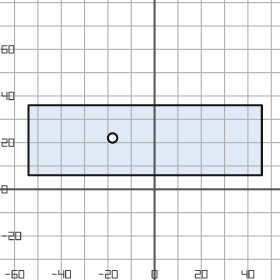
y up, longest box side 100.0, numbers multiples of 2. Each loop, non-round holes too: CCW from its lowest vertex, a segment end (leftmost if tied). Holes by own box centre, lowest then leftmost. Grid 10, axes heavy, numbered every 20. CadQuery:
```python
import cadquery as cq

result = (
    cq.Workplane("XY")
    .moveTo(-54.0, 6.0)
    .lineTo(46.0, 6.0)
    .lineTo(46.0, 36.0)
    .lineTo(-54.0, 36.0)
    .close()
    .moveTo(-18.0, 22.0)
    .circle(2.0)
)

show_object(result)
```